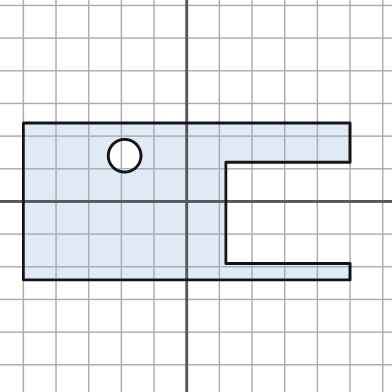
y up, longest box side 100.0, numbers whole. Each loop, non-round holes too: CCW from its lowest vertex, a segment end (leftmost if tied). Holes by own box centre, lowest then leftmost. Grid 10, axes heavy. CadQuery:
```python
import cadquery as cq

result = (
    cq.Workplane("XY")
    .moveTo(-50.0, -24.0)
    .lineTo(50.0, -24.0)
    .lineTo(50.0, -19.0)
    .lineTo(12.0, -19.0)
    .lineTo(12.0, 12.0)
    .lineTo(50.0, 12.0)
    .lineTo(50.0, 24.0)
    .lineTo(-50.0, 24.0)
    .close()
    .moveTo(-19.0, 14.0)
    .circle(5.0)
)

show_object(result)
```